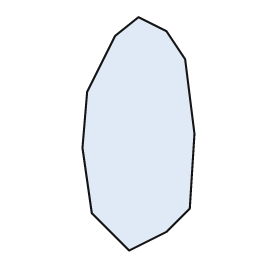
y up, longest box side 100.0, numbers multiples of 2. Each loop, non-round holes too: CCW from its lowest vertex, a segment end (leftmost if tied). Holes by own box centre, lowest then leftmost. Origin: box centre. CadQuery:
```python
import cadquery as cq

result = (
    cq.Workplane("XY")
    .moveTo(-4.0, -50.0)
    .lineTo(12.0, -42.0)
    .lineTo(22.0, -32.0)
    .lineTo(24.0, 0.0)
    .lineTo(20.0, 32.0)
    .lineTo(12.0, 44.0)
    .lineTo(0.0, 50.0)
    .lineTo(-10.0, 42.0)
    .lineTo(-22.0, 18.0)
    .lineTo(-24.0, -6.0)
    .lineTo(-20.0, -34.0)
    .close()
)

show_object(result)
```